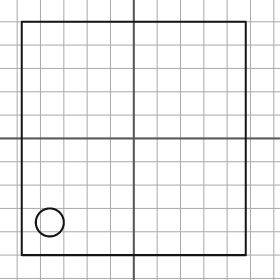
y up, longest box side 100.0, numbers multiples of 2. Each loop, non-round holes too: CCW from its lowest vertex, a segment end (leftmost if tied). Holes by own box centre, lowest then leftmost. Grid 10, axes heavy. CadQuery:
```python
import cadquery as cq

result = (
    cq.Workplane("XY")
    .moveTo(-48.0, -50.0)
    .lineTo(48.0, -50.0)
    .lineTo(48.0, 50.0)
    .lineTo(-48.0, 50.0)
    .close()
    .moveTo(-36.0, -36.0)
    .circle(6.0)
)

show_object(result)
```